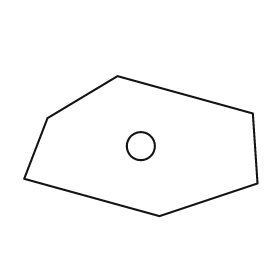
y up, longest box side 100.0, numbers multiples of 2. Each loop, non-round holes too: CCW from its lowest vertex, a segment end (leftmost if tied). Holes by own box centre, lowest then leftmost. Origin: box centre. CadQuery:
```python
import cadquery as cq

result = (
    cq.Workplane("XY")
    .moveTo(8.0, -30.0)
    .lineTo(50.0, -16.0)
    .lineTo(48.0, 14.0)
    .lineTo(-10.0, 30.0)
    .lineTo(-40.0, 12.0)
    .lineTo(-50.0, -14.0)
    .close()
    .moveTo(0.0, 0.0)
    .circle(6.0)
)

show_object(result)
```